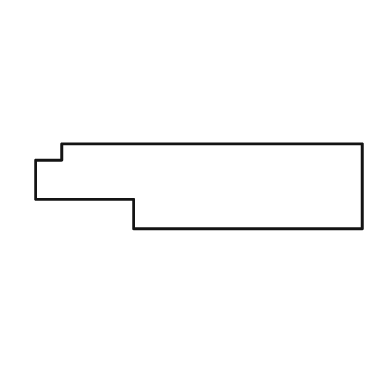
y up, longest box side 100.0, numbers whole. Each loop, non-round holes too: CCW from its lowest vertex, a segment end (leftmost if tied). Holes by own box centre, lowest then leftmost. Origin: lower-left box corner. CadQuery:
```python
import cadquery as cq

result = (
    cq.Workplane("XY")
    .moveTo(30.0, 0.0)
    .lineTo(100.0, 0.0)
    .lineTo(100.0, 26.0)
    .lineTo(8.0, 26.0)
    .lineTo(8.0, 21.0)
    .lineTo(0.0, 21.0)
    .lineTo(0.0, 9.0)
    .lineTo(30.0, 9.0)
    .close()
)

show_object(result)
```